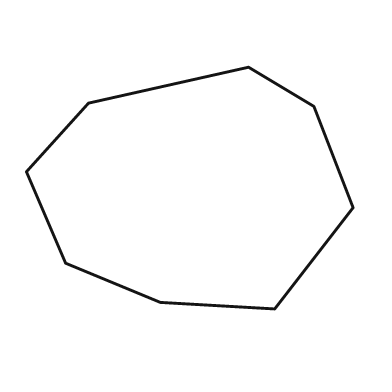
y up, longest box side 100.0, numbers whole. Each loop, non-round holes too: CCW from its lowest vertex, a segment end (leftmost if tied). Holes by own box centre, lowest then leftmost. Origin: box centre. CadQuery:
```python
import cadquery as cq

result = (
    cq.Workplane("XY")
    .moveTo(26.0, -37.0)
    .lineTo(50.0, -6.0)
    .lineTo(38.0, 25.0)
    .lineTo(18.0, 37.0)
    .lineTo(-31.0, 26.0)
    .lineTo(-50.0, 5.0)
    .lineTo(-38.0, -23.0)
    .lineTo(-9.0, -35.0)
    .close()
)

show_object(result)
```